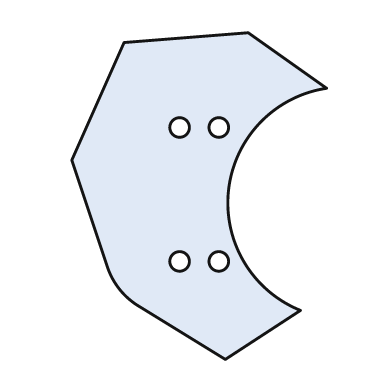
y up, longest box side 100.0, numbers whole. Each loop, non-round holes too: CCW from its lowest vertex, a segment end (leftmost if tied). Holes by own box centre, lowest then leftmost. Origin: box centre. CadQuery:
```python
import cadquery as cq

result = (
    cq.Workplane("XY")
    .moveTo(8.0, -50.0)
    .lineTo(31.0, -35.0)
    .threePointArc((9.0, 2.0), (39.0, 33.0))
    .lineTo(15.0, 50.0)
    .lineTo(-23.0, 47.0)
    .lineTo(-39.0, 11.0)
    .lineTo(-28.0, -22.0)
    .threePointArc((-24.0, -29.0), (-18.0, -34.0))
    .close()
    .moveTo(-6.0, -20.0)
    .circle(3.0)
    .moveTo(6.0, -20.0)
    .circle(3.0)
    .moveTo(-6.0, 21.0)
    .circle(3.0)
    .moveTo(6.0, 21.0)
    .circle(3.0)
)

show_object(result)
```